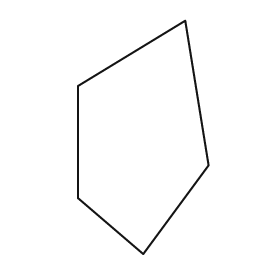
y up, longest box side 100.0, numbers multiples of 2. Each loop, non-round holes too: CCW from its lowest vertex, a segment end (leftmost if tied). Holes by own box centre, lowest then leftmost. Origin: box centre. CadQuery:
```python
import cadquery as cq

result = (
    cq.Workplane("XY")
    .moveTo(0.0, -50.0)
    .lineTo(28.0, -12.0)
    .lineTo(18.0, 50.0)
    .lineTo(-28.0, 22.0)
    .lineTo(-28.0, -26.0)
    .close()
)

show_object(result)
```